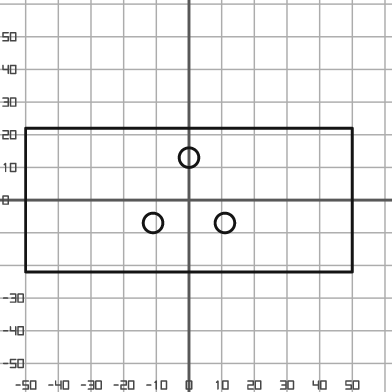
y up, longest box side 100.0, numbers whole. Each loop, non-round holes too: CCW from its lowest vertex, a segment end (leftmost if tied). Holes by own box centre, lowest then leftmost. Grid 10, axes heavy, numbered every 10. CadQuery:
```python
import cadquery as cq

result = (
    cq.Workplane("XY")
    .moveTo(-50.0, -22.0)
    .lineTo(50.0, -22.0)
    .lineTo(50.0, 22.0)
    .lineTo(-50.0, 22.0)
    .close()
    .moveTo(-11.0, -7.0)
    .circle(3.0)
    .moveTo(11.0, -7.0)
    .circle(3.0)
    .moveTo(0.0, 13.0)
    .circle(3.0)
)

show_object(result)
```